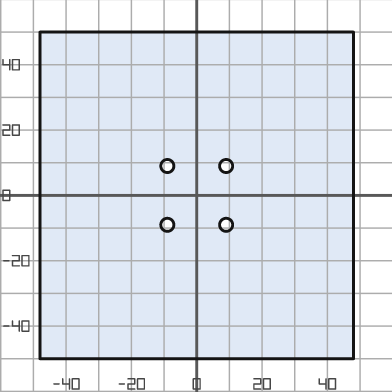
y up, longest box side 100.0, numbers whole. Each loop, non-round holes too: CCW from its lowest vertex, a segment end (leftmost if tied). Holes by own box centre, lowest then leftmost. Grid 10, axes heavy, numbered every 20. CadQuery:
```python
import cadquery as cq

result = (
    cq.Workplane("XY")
    .moveTo(-48.0, -50.0)
    .lineTo(48.0, -50.0)
    .lineTo(48.0, 50.0)
    .lineTo(-48.0, 50.0)
    .close()
    .moveTo(-9.0, -9.0)
    .circle(2.0)
    .moveTo(9.0, -9.0)
    .circle(2.0)
    .moveTo(-9.0, 9.0)
    .circle(2.0)
    .moveTo(9.0, 9.0)
    .circle(2.0)
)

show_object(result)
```